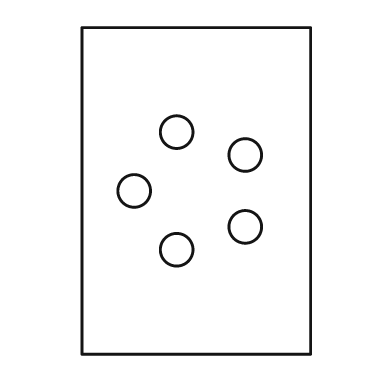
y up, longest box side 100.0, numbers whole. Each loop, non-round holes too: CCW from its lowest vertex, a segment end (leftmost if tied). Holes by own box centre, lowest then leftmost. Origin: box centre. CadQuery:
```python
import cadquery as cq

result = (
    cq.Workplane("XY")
    .moveTo(-35.0, -50.0)
    .lineTo(35.0, -50.0)
    .lineTo(35.0, 50.0)
    .lineTo(-35.0, 50.0)
    .close()
    .moveTo(-6.0, -18.0)
    .circle(5.0)
    .moveTo(15.0, -11.0)
    .circle(5.0)
    .moveTo(-19.0, 0.0)
    .circle(5.0)
    .moveTo(15.0, 11.0)
    .circle(5.0)
    .moveTo(-6.0, 18.0)
    .circle(5.0)
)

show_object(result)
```